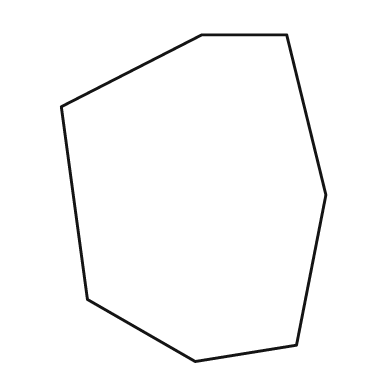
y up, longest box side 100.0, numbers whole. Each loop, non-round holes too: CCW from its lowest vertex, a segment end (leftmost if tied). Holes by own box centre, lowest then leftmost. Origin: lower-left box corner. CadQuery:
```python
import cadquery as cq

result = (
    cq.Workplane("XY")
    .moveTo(41.0, 0.0)
    .lineTo(72.0, 5.0)
    .lineTo(81.0, 51.0)
    .lineTo(69.0, 100.0)
    .lineTo(43.0, 100.0)
    .lineTo(0.0, 78.0)
    .lineTo(8.0, 19.0)
    .close()
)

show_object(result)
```